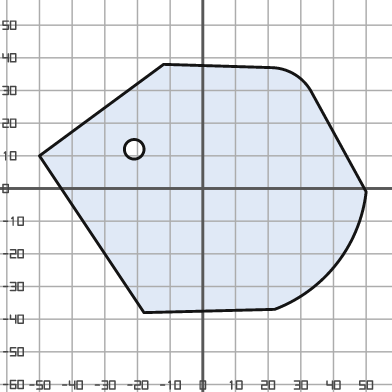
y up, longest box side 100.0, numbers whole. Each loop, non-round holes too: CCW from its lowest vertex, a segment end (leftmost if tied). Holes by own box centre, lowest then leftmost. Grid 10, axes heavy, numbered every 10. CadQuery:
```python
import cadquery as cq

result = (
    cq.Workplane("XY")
    .moveTo(-18.0, -38.0)
    .lineTo(22.0, -37.0)
    .threePointArc((41.0, -23.0), (50.0, -1.0))
    .lineTo(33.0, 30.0)
    .threePointArc((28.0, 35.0), (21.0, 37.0))
    .lineTo(-12.0, 38.0)
    .lineTo(-50.0, 10.0)
    .close()
    .moveTo(-21.0, 12.0)
    .circle(3.0)
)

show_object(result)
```